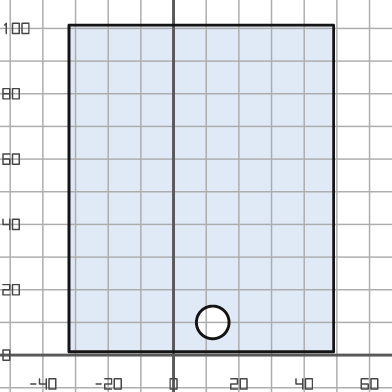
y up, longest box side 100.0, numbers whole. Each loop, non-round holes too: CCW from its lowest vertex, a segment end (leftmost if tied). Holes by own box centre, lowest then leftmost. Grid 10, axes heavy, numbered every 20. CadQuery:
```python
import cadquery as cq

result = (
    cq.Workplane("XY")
    .moveTo(-32.0, 1.0)
    .lineTo(49.0, 1.0)
    .lineTo(49.0, 101.0)
    .lineTo(-32.0, 101.0)
    .close()
    .moveTo(12.0, 10.0)
    .circle(5.0)
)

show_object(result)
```